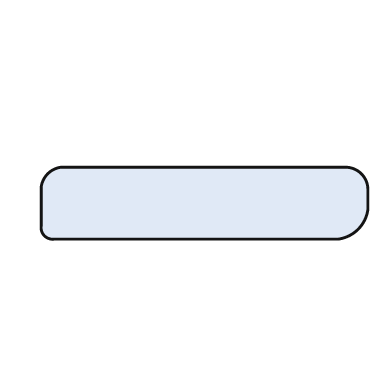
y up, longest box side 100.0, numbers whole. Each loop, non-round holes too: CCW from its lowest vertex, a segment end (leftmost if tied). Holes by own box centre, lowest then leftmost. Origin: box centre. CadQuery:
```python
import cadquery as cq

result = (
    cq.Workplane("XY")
    .moveTo(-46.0, -11.0)
    .lineTo(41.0, -11.0)
    .threePointArc((47.0, -8.0), (50.0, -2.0))
    .lineTo(50.0, 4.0)
    .threePointArc((48.0, 9.0), (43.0, 11.0))
    .lineTo(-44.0, 11.0)
    .threePointArc((-48.0, 9.0), (-50.0, 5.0))
    .lineTo(-50.0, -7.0)
    .threePointArc((-49.0, -10.0), (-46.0, -11.0))
    .close()
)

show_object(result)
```